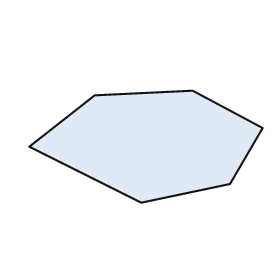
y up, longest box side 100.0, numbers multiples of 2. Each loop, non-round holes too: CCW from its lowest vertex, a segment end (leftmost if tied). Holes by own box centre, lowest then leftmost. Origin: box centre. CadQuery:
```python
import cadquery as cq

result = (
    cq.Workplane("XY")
    .moveTo(-2.0, -24.0)
    .lineTo(36.0, -16.0)
    .lineTo(50.0, 8.0)
    .lineTo(20.0, 24.0)
    .lineTo(-22.0, 22.0)
    .lineTo(-50.0, 0.0)
    .close()
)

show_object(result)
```